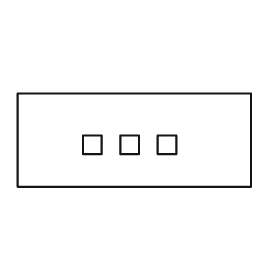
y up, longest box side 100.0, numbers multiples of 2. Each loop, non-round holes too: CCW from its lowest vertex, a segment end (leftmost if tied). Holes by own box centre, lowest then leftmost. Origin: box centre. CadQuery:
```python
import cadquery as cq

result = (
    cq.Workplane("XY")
    .moveTo(-50.0, -20.0)
    .lineTo(50.0, -20.0)
    .lineTo(50.0, 20.0)
    .lineTo(-50.0, 20.0)
    .close()
    .moveTo(-22.0, -6.0)
    .lineTo(-14.0, -6.0)
    .lineTo(-14.0, 2.0)
    .lineTo(-22.0, 2.0)
    .close()
    .moveTo(-6.0, -6.0)
    .lineTo(2.0, -6.0)
    .lineTo(2.0, 2.0)
    .lineTo(-6.0, 2.0)
    .close()
    .moveTo(10.0, -6.0)
    .lineTo(18.0, -6.0)
    .lineTo(18.0, 2.0)
    .lineTo(10.0, 2.0)
    .close()
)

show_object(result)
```